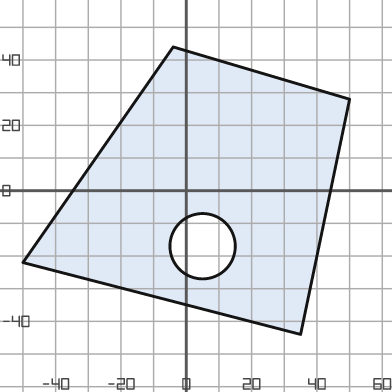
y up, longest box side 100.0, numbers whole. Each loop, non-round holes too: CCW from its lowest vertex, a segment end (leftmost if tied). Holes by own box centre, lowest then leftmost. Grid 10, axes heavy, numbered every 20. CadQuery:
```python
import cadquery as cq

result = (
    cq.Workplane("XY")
    .moveTo(35.0, -44.0)
    .lineTo(50.0, 28.0)
    .lineTo(-4.0, 44.0)
    .lineTo(-50.0, -22.0)
    .close()
    .moveTo(5.0, -17.0)
    .circle(10.0)
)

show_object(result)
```